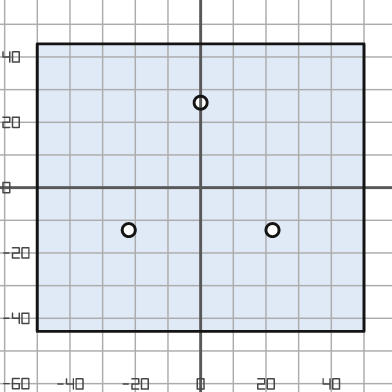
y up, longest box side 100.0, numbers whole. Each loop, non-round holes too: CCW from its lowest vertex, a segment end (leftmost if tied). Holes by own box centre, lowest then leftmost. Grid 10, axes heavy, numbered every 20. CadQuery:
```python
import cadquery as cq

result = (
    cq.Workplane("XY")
    .moveTo(-50.0, -44.0)
    .lineTo(50.0, -44.0)
    .lineTo(50.0, 44.0)
    .lineTo(-50.0, 44.0)
    .close()
    .moveTo(-22.0, -13.0)
    .circle(2.0)
    .moveTo(22.0, -13.0)
    .circle(2.0)
    .moveTo(0.0, 26.0)
    .circle(2.0)
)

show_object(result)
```